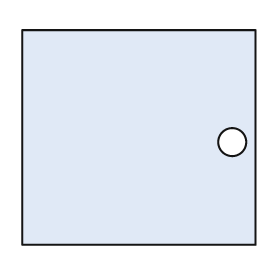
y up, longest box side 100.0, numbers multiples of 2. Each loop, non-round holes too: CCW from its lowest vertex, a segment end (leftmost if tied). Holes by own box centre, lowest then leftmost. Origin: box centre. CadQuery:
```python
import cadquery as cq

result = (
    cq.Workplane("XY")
    .moveTo(-50.0, -46.0)
    .lineTo(50.0, -46.0)
    .lineTo(50.0, 46.0)
    .lineTo(-50.0, 46.0)
    .close()
    .moveTo(40.0, -2.0)
    .circle(6.0)
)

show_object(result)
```